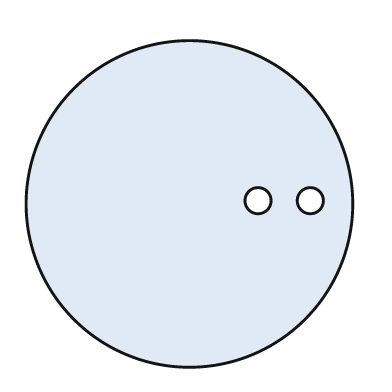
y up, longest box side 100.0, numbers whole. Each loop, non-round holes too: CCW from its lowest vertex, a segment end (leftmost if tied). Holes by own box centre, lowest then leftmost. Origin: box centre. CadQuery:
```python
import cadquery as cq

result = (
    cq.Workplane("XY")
    .moveTo(0.0, 0.0)
    .circle(50.0)
    .moveTo(21.0, 1.0)
    .circle(4.0)
    .moveTo(37.0, 1.0)
    .circle(4.0)
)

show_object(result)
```